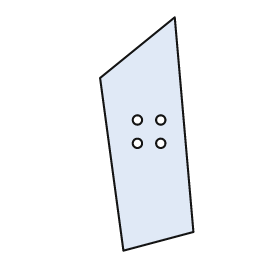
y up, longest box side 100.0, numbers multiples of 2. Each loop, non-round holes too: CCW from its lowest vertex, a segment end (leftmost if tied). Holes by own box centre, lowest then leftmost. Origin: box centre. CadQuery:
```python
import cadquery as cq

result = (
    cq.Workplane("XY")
    .moveTo(-10.0, -50.0)
    .lineTo(20.0, -42.0)
    .lineTo(12.0, 50.0)
    .lineTo(-20.0, 24.0)
    .close()
    .moveTo(-4.0, -4.0)
    .circle(2.0)
    .moveTo(6.0, -4.0)
    .circle(2.0)
    .moveTo(-4.0, 6.0)
    .circle(2.0)
    .moveTo(6.0, 6.0)
    .circle(2.0)
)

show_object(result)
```